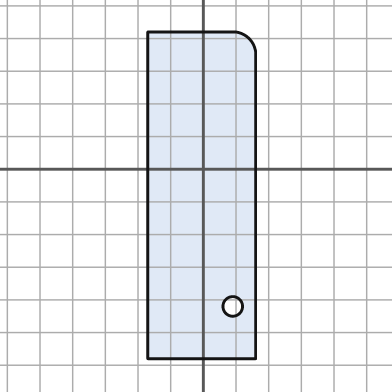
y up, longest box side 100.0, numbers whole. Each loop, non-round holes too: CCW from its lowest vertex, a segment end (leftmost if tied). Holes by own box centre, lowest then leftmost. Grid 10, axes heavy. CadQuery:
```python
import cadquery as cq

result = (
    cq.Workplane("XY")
    .moveTo(-17.0, -58.0)
    .lineTo(16.0, -58.0)
    .lineTo(16.0, 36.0)
    .threePointArc((14.0, 40.0), (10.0, 42.0))
    .lineTo(-17.0, 42.0)
    .close()
    .moveTo(9.0, -42.0)
    .circle(3.0)
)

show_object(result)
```